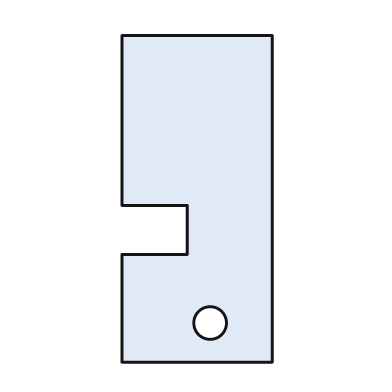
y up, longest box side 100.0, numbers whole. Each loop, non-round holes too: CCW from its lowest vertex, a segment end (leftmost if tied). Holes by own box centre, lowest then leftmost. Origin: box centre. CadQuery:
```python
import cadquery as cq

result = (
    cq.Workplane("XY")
    .moveTo(-23.0, -50.0)
    .lineTo(23.0, -50.0)
    .lineTo(23.0, 50.0)
    .lineTo(-23.0, 50.0)
    .lineTo(-23.0, -2.0)
    .lineTo(-3.0, -2.0)
    .lineTo(-3.0, -17.0)
    .lineTo(-23.0, -17.0)
    .close()
    .moveTo(4.0, -38.0)
    .circle(5.0)
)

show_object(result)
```